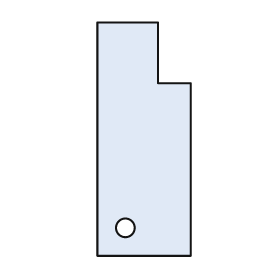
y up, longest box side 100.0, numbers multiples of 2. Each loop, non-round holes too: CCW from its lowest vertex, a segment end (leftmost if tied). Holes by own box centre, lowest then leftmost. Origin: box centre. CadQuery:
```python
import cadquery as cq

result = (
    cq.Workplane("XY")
    .moveTo(-20.0, -50.0)
    .lineTo(20.0, -50.0)
    .lineTo(20.0, 24.0)
    .lineTo(6.0, 24.0)
    .lineTo(6.0, 50.0)
    .lineTo(-20.0, 50.0)
    .close()
    .moveTo(-8.0, -38.0)
    .circle(4.0)
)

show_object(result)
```